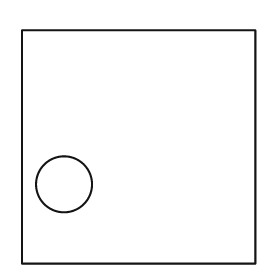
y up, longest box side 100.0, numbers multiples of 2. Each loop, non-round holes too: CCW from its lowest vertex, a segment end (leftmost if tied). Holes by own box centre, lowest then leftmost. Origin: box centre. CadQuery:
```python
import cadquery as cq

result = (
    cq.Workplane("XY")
    .moveTo(-50.0, -50.0)
    .lineTo(50.0, -50.0)
    .lineTo(50.0, 50.0)
    .lineTo(-50.0, 50.0)
    .close()
    .moveTo(-32.0, -16.0)
    .circle(12.0)
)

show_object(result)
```